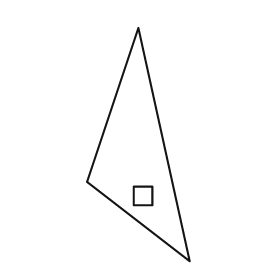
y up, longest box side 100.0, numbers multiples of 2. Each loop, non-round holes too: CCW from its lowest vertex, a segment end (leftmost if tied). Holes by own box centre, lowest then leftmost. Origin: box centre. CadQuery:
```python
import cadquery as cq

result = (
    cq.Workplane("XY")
    .moveTo(22.0, -50.0)
    .lineTo(0.0, 50.0)
    .lineTo(-22.0, -16.0)
    .close()
    .moveTo(-2.0, -26.0)
    .lineTo(6.0, -26.0)
    .lineTo(6.0, -18.0)
    .lineTo(-2.0, -18.0)
    .close()
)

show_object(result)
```